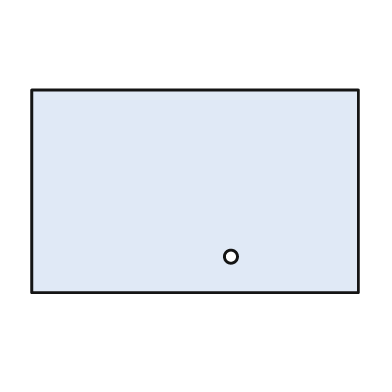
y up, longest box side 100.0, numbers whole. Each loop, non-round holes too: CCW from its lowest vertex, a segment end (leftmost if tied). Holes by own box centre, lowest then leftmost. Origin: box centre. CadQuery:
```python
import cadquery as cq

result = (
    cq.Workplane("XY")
    .moveTo(-50.0, -31.0)
    .lineTo(50.0, -31.0)
    .lineTo(50.0, 31.0)
    .lineTo(-50.0, 31.0)
    .close()
    .moveTo(11.0, -20.0)
    .circle(2.0)
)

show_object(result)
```